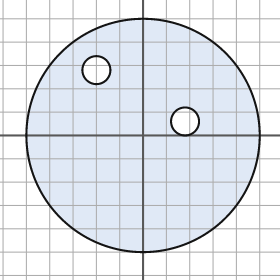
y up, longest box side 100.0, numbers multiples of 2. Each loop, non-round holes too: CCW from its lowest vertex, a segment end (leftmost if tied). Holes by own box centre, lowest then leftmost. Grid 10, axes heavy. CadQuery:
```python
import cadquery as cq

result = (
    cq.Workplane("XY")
    .moveTo(0.0, 0.0)
    .circle(50.0)
    .moveTo(18.0, 6.0)
    .circle(6.0)
    .moveTo(-20.0, 28.0)
    .circle(6.0)
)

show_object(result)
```